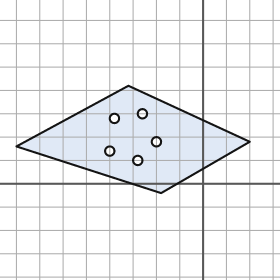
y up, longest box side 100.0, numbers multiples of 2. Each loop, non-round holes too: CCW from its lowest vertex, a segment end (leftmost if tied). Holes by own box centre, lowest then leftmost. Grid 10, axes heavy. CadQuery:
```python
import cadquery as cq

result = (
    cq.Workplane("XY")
    .moveTo(-18.0, -4.0)
    .lineTo(20.0, 18.0)
    .lineTo(-32.0, 42.0)
    .lineTo(-80.0, 16.0)
    .close()
    .moveTo(-28.0, 10.0)
    .circle(2.0)
    .moveTo(-40.0, 14.0)
    .circle(2.0)
    .moveTo(-20.0, 18.0)
    .circle(2.0)
    .moveTo(-38.0, 28.0)
    .circle(2.0)
    .moveTo(-26.0, 30.0)
    .circle(2.0)
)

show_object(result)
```